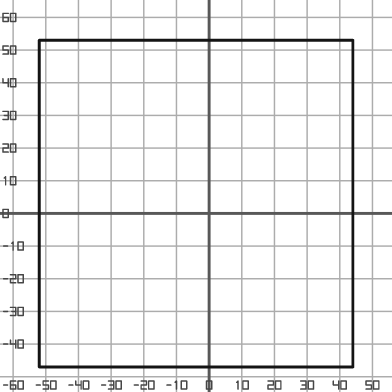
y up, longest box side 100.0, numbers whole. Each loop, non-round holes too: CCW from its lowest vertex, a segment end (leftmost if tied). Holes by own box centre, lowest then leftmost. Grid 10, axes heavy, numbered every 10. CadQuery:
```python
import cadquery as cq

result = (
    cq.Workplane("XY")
    .moveTo(-52.0, -47.0)
    .lineTo(44.0, -47.0)
    .lineTo(44.0, 53.0)
    .lineTo(-52.0, 53.0)
    .close()
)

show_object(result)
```